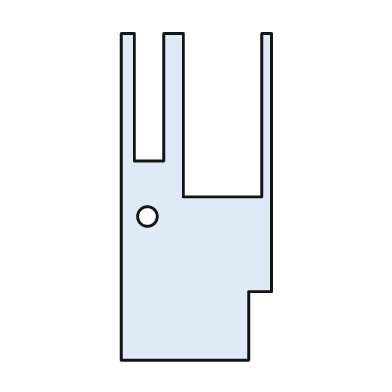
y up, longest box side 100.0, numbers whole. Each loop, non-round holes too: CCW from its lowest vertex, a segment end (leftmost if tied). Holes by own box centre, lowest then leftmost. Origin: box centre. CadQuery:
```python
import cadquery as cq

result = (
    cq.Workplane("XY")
    .moveTo(-23.0, -50.0)
    .lineTo(16.0, -50.0)
    .lineTo(16.0, -29.0)
    .lineTo(23.0, -29.0)
    .lineTo(23.0, 50.0)
    .lineTo(20.0, 50.0)
    .lineTo(20.0, 0.0)
    .lineTo(-4.0, 0.0)
    .lineTo(-4.0, 50.0)
    .lineTo(-10.0, 50.0)
    .lineTo(-10.0, 11.0)
    .lineTo(-19.0, 11.0)
    .lineTo(-19.0, 50.0)
    .lineTo(-23.0, 50.0)
    .close()
    .moveTo(-15.0, -6.0)
    .circle(3.0)
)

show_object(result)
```